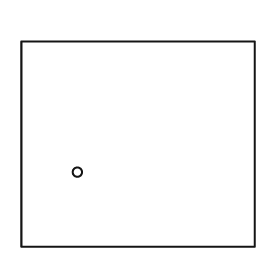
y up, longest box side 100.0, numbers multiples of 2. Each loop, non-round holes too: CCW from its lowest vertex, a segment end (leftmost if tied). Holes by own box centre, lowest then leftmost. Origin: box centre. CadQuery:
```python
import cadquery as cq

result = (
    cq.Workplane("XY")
    .moveTo(-50.0, -44.0)
    .lineTo(50.0, -44.0)
    .lineTo(50.0, 44.0)
    .lineTo(-50.0, 44.0)
    .close()
    .moveTo(-26.0, -12.0)
    .circle(2.0)
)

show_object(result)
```